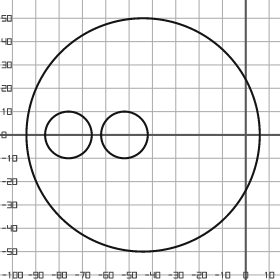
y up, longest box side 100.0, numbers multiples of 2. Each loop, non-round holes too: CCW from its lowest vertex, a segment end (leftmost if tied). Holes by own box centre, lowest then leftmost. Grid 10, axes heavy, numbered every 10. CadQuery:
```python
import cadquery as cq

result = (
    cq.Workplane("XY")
    .moveTo(-44.0, 0.0)
    .circle(50.0)
    .moveTo(-76.0, 0.0)
    .circle(10.0)
    .moveTo(-52.0, 0.0)
    .circle(10.0)
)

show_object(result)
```